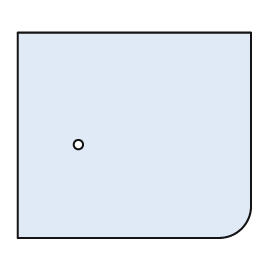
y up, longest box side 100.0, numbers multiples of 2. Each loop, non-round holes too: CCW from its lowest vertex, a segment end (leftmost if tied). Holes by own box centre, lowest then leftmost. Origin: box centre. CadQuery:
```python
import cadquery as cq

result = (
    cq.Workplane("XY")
    .moveTo(-50.0, -44.0)
    .lineTo(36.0, -44.0)
    .threePointArc((46.0, -40.0), (50.0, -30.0))
    .lineTo(50.0, 44.0)
    .lineTo(-50.0, 44.0)
    .close()
    .moveTo(-24.0, -4.0)
    .circle(2.0)
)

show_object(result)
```